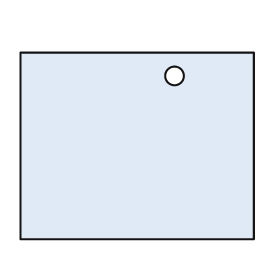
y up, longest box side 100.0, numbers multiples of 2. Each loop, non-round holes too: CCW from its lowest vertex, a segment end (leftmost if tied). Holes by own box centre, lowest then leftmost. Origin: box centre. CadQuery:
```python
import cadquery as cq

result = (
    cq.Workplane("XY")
    .moveTo(-50.0, -40.0)
    .lineTo(50.0, -40.0)
    .lineTo(50.0, 40.0)
    .lineTo(-50.0, 40.0)
    .close()
    .moveTo(16.0, 30.0)
    .circle(4.0)
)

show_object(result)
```